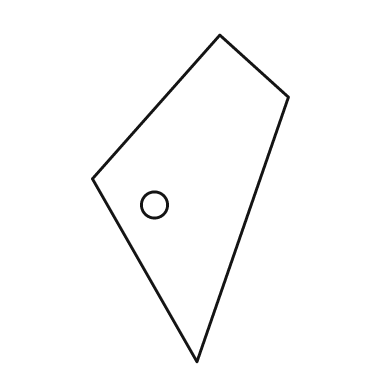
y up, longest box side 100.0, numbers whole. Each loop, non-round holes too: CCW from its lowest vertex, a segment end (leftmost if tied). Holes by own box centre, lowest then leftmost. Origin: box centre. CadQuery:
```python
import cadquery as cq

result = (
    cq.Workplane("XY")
    .moveTo(2.0, -50.0)
    .lineTo(30.0, 31.0)
    .lineTo(9.0, 50.0)
    .lineTo(-30.0, 6.0)
    .close()
    .moveTo(-11.0, -2.0)
    .circle(4.0)
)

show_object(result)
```